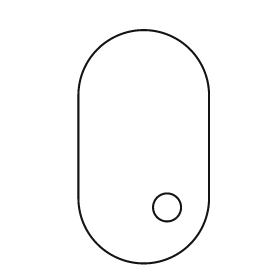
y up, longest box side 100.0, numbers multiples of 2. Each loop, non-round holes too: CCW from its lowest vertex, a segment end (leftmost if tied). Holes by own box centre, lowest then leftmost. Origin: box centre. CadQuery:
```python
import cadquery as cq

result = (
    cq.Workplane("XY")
    .moveTo(-28.0, -22.0)
    .threePointArc((0.0, -50.0), (28.0, -22.0))
    .lineTo(28.0, 22.0)
    .threePointArc((0.0, 50.0), (-28.0, 22.0))
    .close()
    .moveTo(10.0, -26.0)
    .circle(6.0)
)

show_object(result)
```